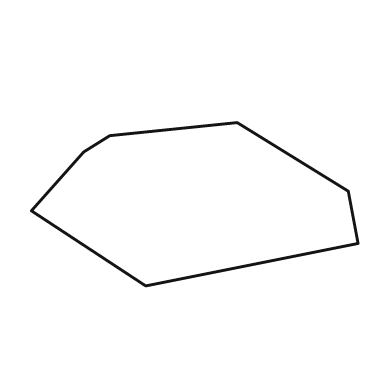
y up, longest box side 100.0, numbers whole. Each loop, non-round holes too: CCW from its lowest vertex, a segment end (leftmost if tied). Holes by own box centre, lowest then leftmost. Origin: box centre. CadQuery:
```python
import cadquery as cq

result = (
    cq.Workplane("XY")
    .moveTo(-15.0, -25.0)
    .lineTo(50.0, -12.0)
    .lineTo(47.0, 4.0)
    .lineTo(13.0, 25.0)
    .lineTo(-26.0, 21.0)
    .lineTo(-34.0, 16.0)
    .lineTo(-50.0, -2.0)
    .close()
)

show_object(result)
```